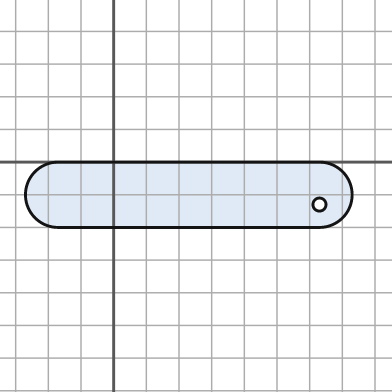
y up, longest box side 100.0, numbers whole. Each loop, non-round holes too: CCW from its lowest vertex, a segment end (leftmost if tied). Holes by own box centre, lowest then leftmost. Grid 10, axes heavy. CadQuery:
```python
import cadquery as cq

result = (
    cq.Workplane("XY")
    .moveTo(-17.0, -20.0)
    .lineTo(63.0, -20.0)
    .threePointArc((73.0, -10.0), (63.0, 0.0))
    .lineTo(-17.0, 0.0)
    .threePointArc((-27.0, -10.0), (-17.0, -20.0))
    .close()
    .moveTo(63.0, -13.0)
    .circle(2.0)
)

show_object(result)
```